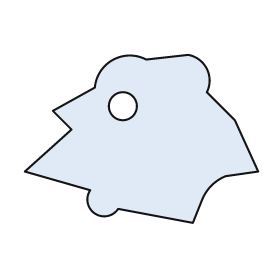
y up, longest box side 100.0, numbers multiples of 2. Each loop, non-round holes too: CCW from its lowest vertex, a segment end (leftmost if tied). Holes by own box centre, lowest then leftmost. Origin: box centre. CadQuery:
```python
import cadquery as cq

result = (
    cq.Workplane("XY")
    .moveTo(22.0, -36.0)
    .lineTo(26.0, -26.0)
    .threePointArc((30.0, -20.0), (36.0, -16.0))
    .lineTo(50.0, -14.0)
    .lineTo(40.0, 8.0)
    .lineTo(28.0, 20.0)
    .threePointArc((28.0, 30.0), (20.0, 36.0))
    .lineTo(2.0, 34.0)
    .threePointArc((-12.0, 34.0), (-20.0, 22.0))
    .lineTo(-38.0, 12.0)
    .lineTo(-30.0, 4.0)
    .lineTo(-50.0, -14.0)
    .lineTo(-22.0, -22.0)
    .threePointArc((-20.0, -32.0), (-10.0, -30.0))
    .close()
    .moveTo(-8.0, 14.0)
    .circle(6.0)
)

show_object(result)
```